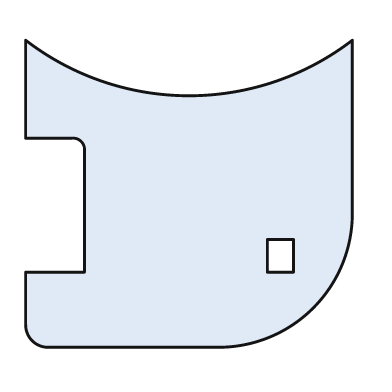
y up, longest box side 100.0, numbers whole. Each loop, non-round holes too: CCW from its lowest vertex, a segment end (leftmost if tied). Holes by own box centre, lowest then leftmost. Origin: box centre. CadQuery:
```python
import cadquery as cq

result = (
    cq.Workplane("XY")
    .moveTo(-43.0, -47.0)
    .lineTo(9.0, -47.0)
    .threePointArc((38.0, -35.0), (50.0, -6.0))
    .lineTo(50.0, 47.0)
    .threePointArc((0.0, 30.0), (-50.0, 47.0))
    .lineTo(-50.0, 17.0)
    .lineTo(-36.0, 17.0)
    .threePointArc((-33.0, 16.0), (-32.0, 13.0))
    .lineTo(-32.0, -24.0)
    .lineTo(-50.0, -24.0)
    .lineTo(-50.0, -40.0)
    .threePointArc((-48.0, -45.0), (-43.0, -47.0))
    .close()
    .moveTo(24.0, -24.0)
    .lineTo(32.0, -24.0)
    .lineTo(32.0, -14.0)
    .lineTo(24.0, -14.0)
    .close()
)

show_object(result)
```